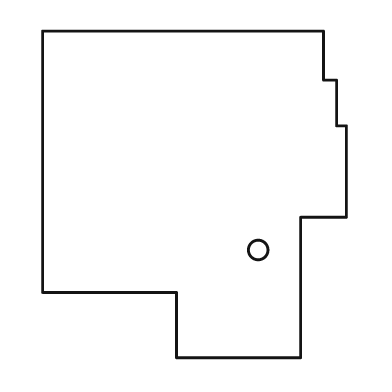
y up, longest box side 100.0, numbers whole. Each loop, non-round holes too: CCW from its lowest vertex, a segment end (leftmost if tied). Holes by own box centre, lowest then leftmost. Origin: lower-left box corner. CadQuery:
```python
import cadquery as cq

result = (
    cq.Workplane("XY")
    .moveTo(41.0, 0.0)
    .lineTo(79.0, 0.0)
    .lineTo(79.0, 43.0)
    .lineTo(93.0, 43.0)
    .lineTo(93.0, 71.0)
    .lineTo(90.0, 71.0)
    .lineTo(90.0, 85.0)
    .lineTo(86.0, 85.0)
    .lineTo(86.0, 100.0)
    .lineTo(0.0, 100.0)
    .lineTo(0.0, 20.0)
    .lineTo(41.0, 20.0)
    .close()
    .moveTo(66.0, 33.0)
    .circle(3.0)
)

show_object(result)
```